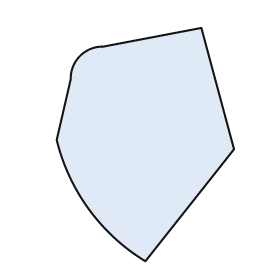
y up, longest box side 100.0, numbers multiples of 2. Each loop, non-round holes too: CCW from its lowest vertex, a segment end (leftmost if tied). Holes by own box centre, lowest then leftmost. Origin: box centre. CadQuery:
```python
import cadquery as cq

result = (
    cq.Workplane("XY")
    .moveTo(0.0, -50.0)
    .lineTo(38.0, -2.0)
    .lineTo(24.0, 50.0)
    .lineTo(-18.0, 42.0)
    .threePointArc((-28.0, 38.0), (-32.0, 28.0))
    .lineTo(-38.0, 2.0)
    .threePointArc((-24.0, -28.0), (0.0, -50.0))
    .close()
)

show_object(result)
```